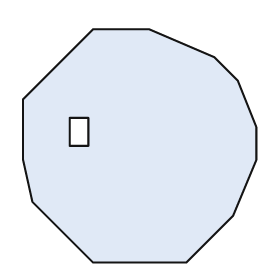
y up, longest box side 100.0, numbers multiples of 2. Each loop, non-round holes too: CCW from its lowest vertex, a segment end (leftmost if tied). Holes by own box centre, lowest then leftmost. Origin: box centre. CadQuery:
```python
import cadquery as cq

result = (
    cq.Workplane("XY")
    .moveTo(-20.0, -50.0)
    .lineTo(20.0, -50.0)
    .lineTo(40.0, -30.0)
    .lineTo(50.0, -6.0)
    .lineTo(50.0, 8.0)
    .lineTo(42.0, 28.0)
    .lineTo(32.0, 38.0)
    .lineTo(4.0, 50.0)
    .lineTo(-20.0, 50.0)
    .lineTo(-50.0, 20.0)
    .lineTo(-50.0, -6.0)
    .lineTo(-46.0, -24.0)
    .close()
    .moveTo(-30.0, 0.0)
    .lineTo(-22.0, 0.0)
    .lineTo(-22.0, 12.0)
    .lineTo(-30.0, 12.0)
    .close()
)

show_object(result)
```